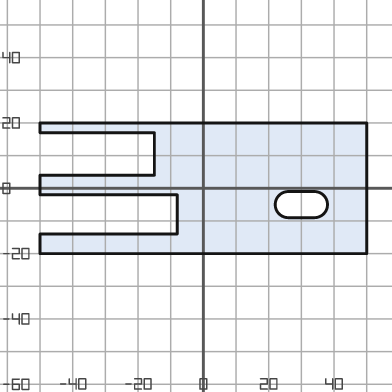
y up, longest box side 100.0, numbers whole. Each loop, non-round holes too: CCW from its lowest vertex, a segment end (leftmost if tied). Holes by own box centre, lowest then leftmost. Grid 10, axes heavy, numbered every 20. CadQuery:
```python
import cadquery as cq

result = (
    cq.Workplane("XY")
    .moveTo(-50.0, -20.0)
    .lineTo(50.0, -20.0)
    .lineTo(50.0, 20.0)
    .lineTo(-50.0, 20.0)
    .lineTo(-50.0, 17.0)
    .lineTo(-15.0, 17.0)
    .lineTo(-15.0, 4.0)
    .lineTo(-50.0, 4.0)
    .lineTo(-50.0, -2.0)
    .lineTo(-8.0, -2.0)
    .lineTo(-8.0, -14.0)
    .lineTo(-50.0, -14.0)
    .close()
    .moveTo(26.0, -9.0)
    .lineTo(34.0, -9.0)
    .threePointArc((38.0, -5.0), (34.0, -1.0))
    .lineTo(26.0, -1.0)
    .threePointArc((22.0, -5.0), (26.0, -9.0))
    .close()
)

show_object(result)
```